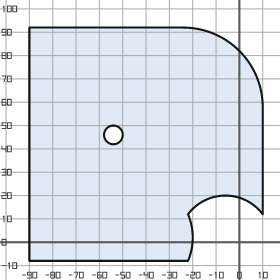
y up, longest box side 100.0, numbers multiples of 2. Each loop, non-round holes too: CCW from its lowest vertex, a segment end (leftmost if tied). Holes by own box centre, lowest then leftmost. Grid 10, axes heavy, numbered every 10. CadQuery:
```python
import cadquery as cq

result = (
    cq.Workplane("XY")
    .moveTo(-90.0, -8.0)
    .lineTo(-22.0, -8.0)
    .threePointArc((-20.0, 2.0), (-22.0, 12.0))
    .threePointArc((-6.0, 20.0), (10.0, 12.0))
    .lineTo(10.0, 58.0)
    .threePointArc((0.0, 82.0), (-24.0, 92.0))
    .lineTo(-90.0, 92.0)
    .close()
    .moveTo(-54.0, 46.0)
    .circle(4.0)
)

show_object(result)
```